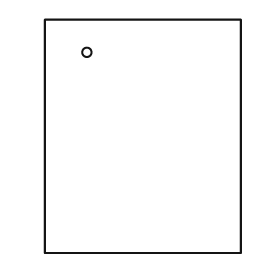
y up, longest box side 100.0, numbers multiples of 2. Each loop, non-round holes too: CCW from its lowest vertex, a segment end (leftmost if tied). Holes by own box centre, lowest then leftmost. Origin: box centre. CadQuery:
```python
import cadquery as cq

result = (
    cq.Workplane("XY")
    .moveTo(-42.0, -50.0)
    .lineTo(42.0, -50.0)
    .lineTo(42.0, 50.0)
    .lineTo(-42.0, 50.0)
    .close()
    .moveTo(-24.0, 36.0)
    .circle(2.0)
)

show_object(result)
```